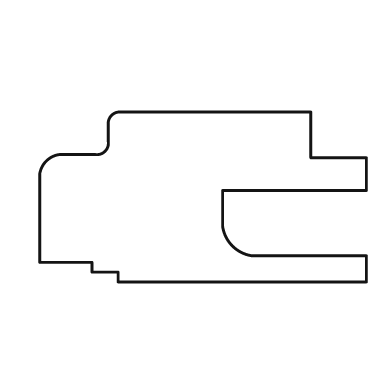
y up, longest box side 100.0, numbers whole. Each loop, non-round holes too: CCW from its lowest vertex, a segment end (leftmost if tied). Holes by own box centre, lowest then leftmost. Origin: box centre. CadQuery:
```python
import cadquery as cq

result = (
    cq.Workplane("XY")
    .moveTo(-26.0, -26.0)
    .lineTo(50.0, -26.0)
    .lineTo(50.0, -18.0)
    .lineTo(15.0, -18.0)
    .threePointArc((9.0, -15.0), (6.0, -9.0))
    .lineTo(6.0, 2.0)
    .lineTo(50.0, 2.0)
    .lineTo(50.0, 12.0)
    .lineTo(33.0, 12.0)
    .lineTo(33.0, 26.0)
    .lineTo(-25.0, 26.0)
    .threePointArc((-28.0, 25.0), (-29.0, 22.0))
    .lineTo(-29.0, 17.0)
    .threePointArc((-30.0, 14.0), (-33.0, 13.0))
    .lineTo(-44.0, 13.0)
    .threePointArc((-48.0, 11.0), (-50.0, 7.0))
    .lineTo(-50.0, -20.0)
    .lineTo(-34.0, -20.0)
    .lineTo(-34.0, -23.0)
    .lineTo(-26.0, -23.0)
    .close()
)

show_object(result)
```